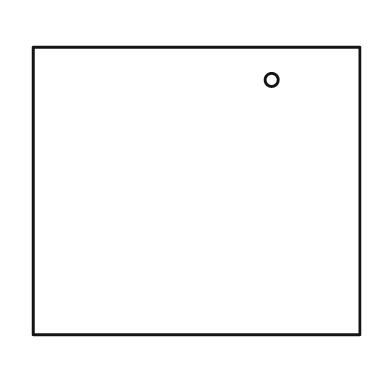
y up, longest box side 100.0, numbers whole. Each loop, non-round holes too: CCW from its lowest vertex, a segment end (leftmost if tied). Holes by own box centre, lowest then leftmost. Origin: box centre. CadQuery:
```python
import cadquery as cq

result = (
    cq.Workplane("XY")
    .moveTo(-50.0, -44.0)
    .lineTo(50.0, -44.0)
    .lineTo(50.0, 44.0)
    .lineTo(-50.0, 44.0)
    .close()
    .moveTo(23.0, 34.0)
    .circle(2.0)
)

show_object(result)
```